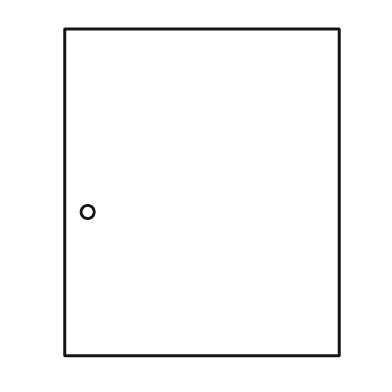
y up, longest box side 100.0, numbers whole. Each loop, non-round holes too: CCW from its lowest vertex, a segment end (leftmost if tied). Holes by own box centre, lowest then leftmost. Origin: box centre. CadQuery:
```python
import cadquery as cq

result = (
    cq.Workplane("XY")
    .moveTo(-42.0, -50.0)
    .lineTo(42.0, -50.0)
    .lineTo(42.0, 50.0)
    .lineTo(-42.0, 50.0)
    .close()
    .moveTo(-35.0, -6.0)
    .circle(2.0)
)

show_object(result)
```